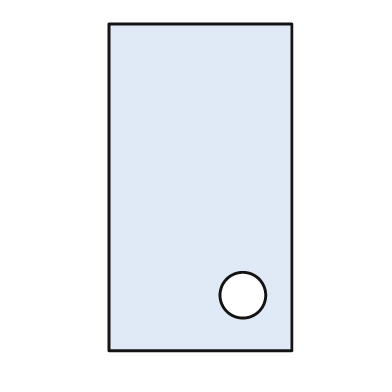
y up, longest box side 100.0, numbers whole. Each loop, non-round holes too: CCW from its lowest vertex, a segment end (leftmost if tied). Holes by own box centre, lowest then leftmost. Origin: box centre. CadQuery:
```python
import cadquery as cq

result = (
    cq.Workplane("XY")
    .moveTo(-28.0, -50.0)
    .lineTo(28.0, -50.0)
    .lineTo(28.0, 50.0)
    .lineTo(-28.0, 50.0)
    .close()
    .moveTo(13.0, -33.0)
    .circle(7.0)
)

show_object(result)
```